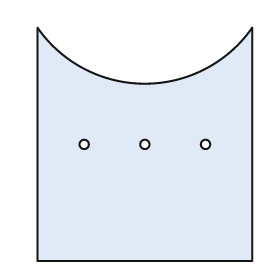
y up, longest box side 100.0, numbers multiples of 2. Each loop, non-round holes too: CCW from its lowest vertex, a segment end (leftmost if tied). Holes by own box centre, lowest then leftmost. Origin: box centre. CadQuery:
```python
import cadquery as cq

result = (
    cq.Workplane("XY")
    .moveTo(-46.0, -50.0)
    .lineTo(46.0, -50.0)
    .lineTo(46.0, 50.0)
    .threePointArc((0.0, 26.0), (-46.0, 50.0))
    .close()
    .moveTo(-26.0, 0.0)
    .circle(2.0)
    .moveTo(0.0, 0.0)
    .circle(2.0)
    .moveTo(26.0, 0.0)
    .circle(2.0)
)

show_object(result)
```